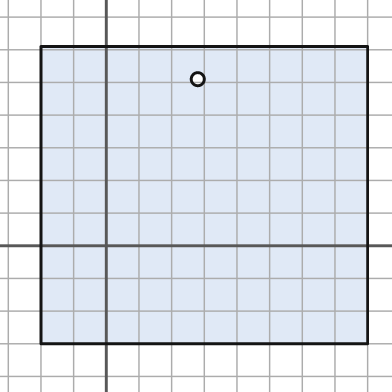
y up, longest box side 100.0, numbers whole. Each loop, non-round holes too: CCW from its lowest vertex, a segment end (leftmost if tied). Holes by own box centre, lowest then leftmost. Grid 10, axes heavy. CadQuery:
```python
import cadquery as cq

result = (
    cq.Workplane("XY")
    .moveTo(-20.0, -30.0)
    .lineTo(80.0, -30.0)
    .lineTo(80.0, 61.0)
    .lineTo(-20.0, 61.0)
    .close()
    .moveTo(28.0, 51.0)
    .circle(2.0)
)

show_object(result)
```